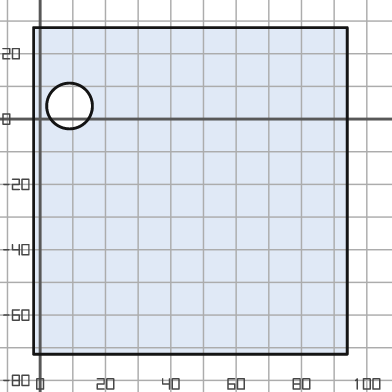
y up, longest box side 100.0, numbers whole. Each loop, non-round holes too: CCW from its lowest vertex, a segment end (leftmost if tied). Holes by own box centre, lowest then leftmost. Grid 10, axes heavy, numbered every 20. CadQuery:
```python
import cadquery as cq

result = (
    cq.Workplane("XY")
    .moveTo(-2.0, -72.0)
    .lineTo(94.0, -72.0)
    .lineTo(94.0, 28.0)
    .lineTo(-2.0, 28.0)
    .close()
    .moveTo(9.0, 4.0)
    .circle(7.0)
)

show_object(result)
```